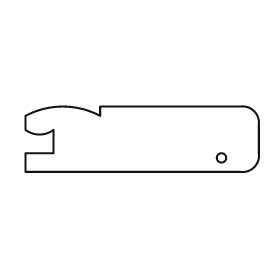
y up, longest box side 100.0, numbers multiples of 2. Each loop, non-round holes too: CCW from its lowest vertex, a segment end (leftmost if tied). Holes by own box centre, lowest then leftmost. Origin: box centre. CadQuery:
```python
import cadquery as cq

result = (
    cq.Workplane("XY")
    .moveTo(-50.0, -14.0)
    .lineTo(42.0, -14.0)
    .threePointArc((48.0, -12.0), (50.0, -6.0))
    .lineTo(50.0, 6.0)
    .threePointArc((48.0, 12.0), (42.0, 14.0))
    .lineTo(-18.0, 14.0)
    .lineTo(-18.0, 10.0)
    .threePointArc((-34.0, 14.0), (-50.0, 10.0))
    .lineTo(-50.0, 4.0)
    .threePointArc((-44.0, 2.0), (-38.0, 4.0))
    .lineTo(-38.0, -6.0)
    .lineTo(-50.0, -6.0)
    .close()
    .moveTo(34.0, -8.0)
    .circle(2.0)
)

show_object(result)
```